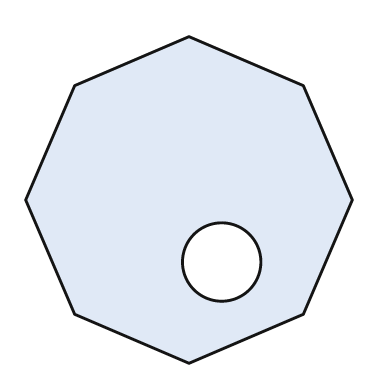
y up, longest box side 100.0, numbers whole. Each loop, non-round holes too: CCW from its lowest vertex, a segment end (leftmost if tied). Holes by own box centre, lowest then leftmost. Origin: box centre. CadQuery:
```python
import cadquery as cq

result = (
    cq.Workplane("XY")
    .moveTo(0.0, -50.0)
    .lineTo(35.0, -35.0)
    .lineTo(50.0, 0.0)
    .lineTo(35.0, 35.0)
    .lineTo(0.0, 50.0)
    .lineTo(-35.0, 35.0)
    .lineTo(-50.0, 0.0)
    .lineTo(-35.0, -35.0)
    .close()
    .moveTo(10.0, -19.0)
    .circle(12.0)
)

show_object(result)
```